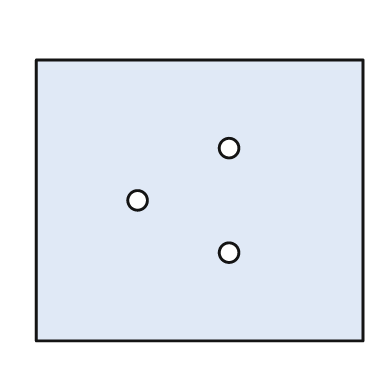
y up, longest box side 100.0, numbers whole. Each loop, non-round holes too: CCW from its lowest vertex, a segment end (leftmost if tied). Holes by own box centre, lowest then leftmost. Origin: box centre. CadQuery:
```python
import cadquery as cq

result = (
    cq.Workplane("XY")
    .moveTo(-50.0, -43.0)
    .lineTo(50.0, -43.0)
    .lineTo(50.0, 43.0)
    .lineTo(-50.0, 43.0)
    .close()
    .moveTo(9.0, -16.0)
    .circle(3.0)
    .moveTo(-19.0, 0.0)
    .circle(3.0)
    .moveTo(9.0, 16.0)
    .circle(3.0)
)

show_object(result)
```